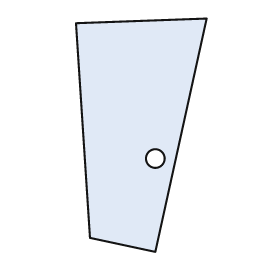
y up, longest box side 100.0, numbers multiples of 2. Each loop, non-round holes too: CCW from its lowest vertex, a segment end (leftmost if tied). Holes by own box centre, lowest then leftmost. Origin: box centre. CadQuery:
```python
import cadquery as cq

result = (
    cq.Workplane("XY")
    .moveTo(6.0, -50.0)
    .lineTo(28.0, 50.0)
    .lineTo(-28.0, 48.0)
    .lineTo(-22.0, -44.0)
    .close()
    .moveTo(6.0, -10.0)
    .circle(4.0)
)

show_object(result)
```